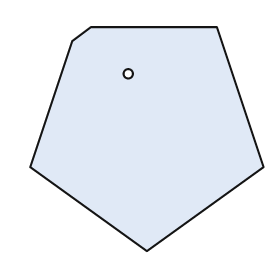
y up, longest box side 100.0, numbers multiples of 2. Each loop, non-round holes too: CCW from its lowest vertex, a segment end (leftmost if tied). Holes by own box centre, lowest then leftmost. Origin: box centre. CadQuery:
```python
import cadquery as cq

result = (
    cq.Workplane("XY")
    .moveTo(0.0, -48.0)
    .lineTo(50.0, -12.0)
    .lineTo(30.0, 48.0)
    .lineTo(-24.0, 48.0)
    .lineTo(-32.0, 42.0)
    .lineTo(-50.0, -12.0)
    .close()
    .moveTo(-8.0, 28.0)
    .circle(2.0)
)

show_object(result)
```